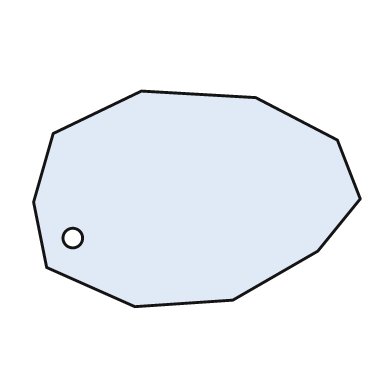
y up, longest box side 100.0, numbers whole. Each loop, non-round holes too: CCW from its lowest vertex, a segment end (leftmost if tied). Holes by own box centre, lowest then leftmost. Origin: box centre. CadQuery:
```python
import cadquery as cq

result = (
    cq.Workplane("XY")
    .moveTo(-19.0, -33.0)
    .lineTo(11.0, -31.0)
    .lineTo(37.0, -16.0)
    .lineTo(50.0, 0.0)
    .lineTo(43.0, 18.0)
    .lineTo(18.0, 31.0)
    .lineTo(-17.0, 33.0)
    .lineTo(-44.0, 20.0)
    .lineTo(-50.0, -1.0)
    .lineTo(-46.0, -21.0)
    .close()
    .moveTo(-38.0, -12.0)
    .circle(3.0)
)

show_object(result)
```